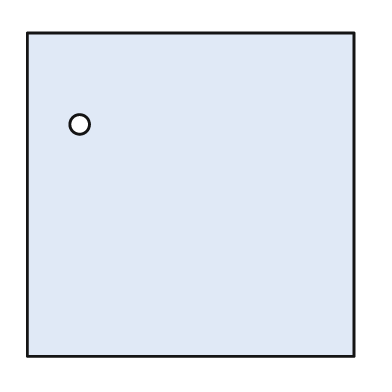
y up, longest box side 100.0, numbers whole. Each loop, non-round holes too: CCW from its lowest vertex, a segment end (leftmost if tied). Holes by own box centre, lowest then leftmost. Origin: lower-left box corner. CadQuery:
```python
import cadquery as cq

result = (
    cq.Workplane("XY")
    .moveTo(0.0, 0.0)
    .lineTo(100.0, 0.0)
    .lineTo(100.0, 99.0)
    .lineTo(0.0, 99.0)
    .close()
    .moveTo(16.0, 71.0)
    .circle(3.0)
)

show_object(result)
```